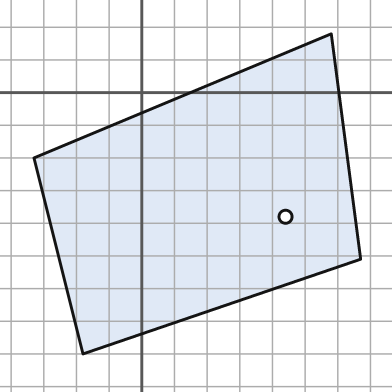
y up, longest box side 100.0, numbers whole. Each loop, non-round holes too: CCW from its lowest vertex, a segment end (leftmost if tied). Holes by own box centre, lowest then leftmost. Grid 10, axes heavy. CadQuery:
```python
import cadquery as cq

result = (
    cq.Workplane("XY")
    .moveTo(-18.0, -80.0)
    .lineTo(67.0, -51.0)
    .lineTo(58.0, 18.0)
    .lineTo(-33.0, -20.0)
    .close()
    .moveTo(44.0, -38.0)
    .circle(2.0)
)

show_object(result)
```